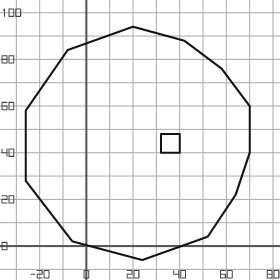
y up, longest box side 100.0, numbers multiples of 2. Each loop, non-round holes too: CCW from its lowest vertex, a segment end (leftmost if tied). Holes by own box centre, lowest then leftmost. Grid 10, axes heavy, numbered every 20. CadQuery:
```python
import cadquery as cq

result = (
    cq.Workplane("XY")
    .moveTo(24.0, -6.0)
    .lineTo(52.0, 4.0)
    .lineTo(64.0, 22.0)
    .lineTo(70.0, 40.0)
    .lineTo(70.0, 60.0)
    .lineTo(58.0, 76.0)
    .lineTo(42.0, 88.0)
    .lineTo(20.0, 94.0)
    .lineTo(-8.0, 84.0)
    .lineTo(-26.0, 58.0)
    .lineTo(-26.0, 28.0)
    .lineTo(-6.0, 2.0)
    .close()
    .moveTo(32.0, 40.0)
    .lineTo(40.0, 40.0)
    .lineTo(40.0, 48.0)
    .lineTo(32.0, 48.0)
    .close()
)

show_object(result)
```